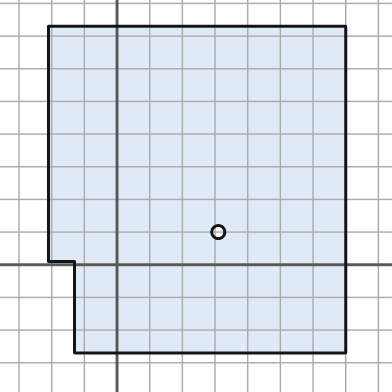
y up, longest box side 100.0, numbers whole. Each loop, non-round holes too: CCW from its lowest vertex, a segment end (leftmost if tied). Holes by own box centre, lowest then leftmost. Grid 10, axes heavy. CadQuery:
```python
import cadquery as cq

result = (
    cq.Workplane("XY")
    .moveTo(-13.0, -27.0)
    .lineTo(70.0, -27.0)
    .lineTo(70.0, 73.0)
    .lineTo(-21.0, 73.0)
    .lineTo(-21.0, 1.0)
    .lineTo(-13.0, 1.0)
    .close()
    .moveTo(31.0, 10.0)
    .circle(2.0)
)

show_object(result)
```